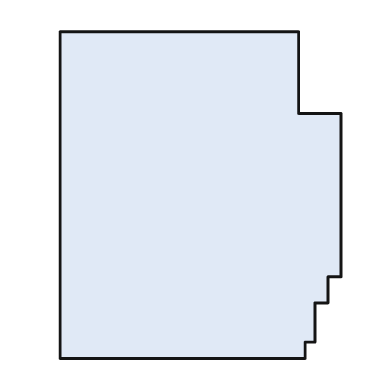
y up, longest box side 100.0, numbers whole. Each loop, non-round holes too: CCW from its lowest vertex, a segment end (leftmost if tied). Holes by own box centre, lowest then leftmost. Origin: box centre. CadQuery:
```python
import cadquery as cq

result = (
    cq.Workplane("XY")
    .moveTo(-43.0, -50.0)
    .lineTo(32.0, -50.0)
    .lineTo(32.0, -45.0)
    .lineTo(35.0, -45.0)
    .lineTo(35.0, -33.0)
    .lineTo(39.0, -33.0)
    .lineTo(39.0, -25.0)
    .lineTo(43.0, -25.0)
    .lineTo(43.0, 25.0)
    .lineTo(30.0, 25.0)
    .lineTo(30.0, 50.0)
    .lineTo(-43.0, 50.0)
    .close()
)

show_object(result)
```